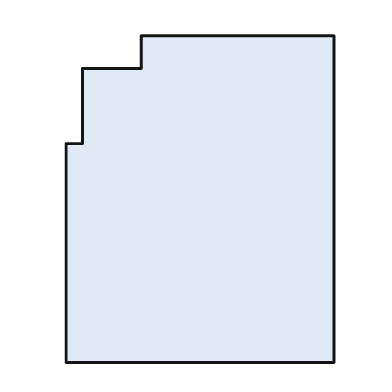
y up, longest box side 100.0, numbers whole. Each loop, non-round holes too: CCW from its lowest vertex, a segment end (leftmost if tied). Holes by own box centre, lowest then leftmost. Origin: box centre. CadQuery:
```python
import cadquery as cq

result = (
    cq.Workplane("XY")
    .moveTo(-41.0, -50.0)
    .lineTo(41.0, -50.0)
    .lineTo(41.0, 50.0)
    .lineTo(-18.0, 50.0)
    .lineTo(-18.0, 40.0)
    .lineTo(-36.0, 40.0)
    .lineTo(-36.0, 17.0)
    .lineTo(-41.0, 17.0)
    .close()
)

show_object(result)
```